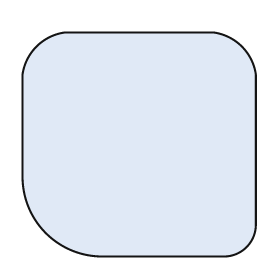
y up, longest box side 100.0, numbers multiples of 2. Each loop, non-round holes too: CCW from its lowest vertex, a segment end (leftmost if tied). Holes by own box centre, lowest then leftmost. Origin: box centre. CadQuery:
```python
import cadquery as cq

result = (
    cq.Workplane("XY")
    .moveTo(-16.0, -48.0)
    .lineTo(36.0, -48.0)
    .threePointArc((46.0, -44.0), (50.0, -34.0))
    .lineTo(50.0, 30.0)
    .threePointArc((44.0, 42.0), (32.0, 48.0))
    .lineTo(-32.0, 48.0)
    .threePointArc((-44.0, 42.0), (-50.0, 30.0))
    .lineTo(-50.0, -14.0)
    .threePointArc((-40.0, -38.0), (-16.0, -48.0))
    .close()
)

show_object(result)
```